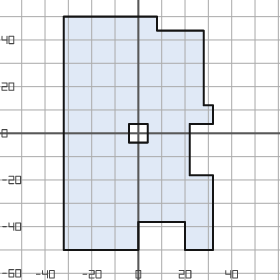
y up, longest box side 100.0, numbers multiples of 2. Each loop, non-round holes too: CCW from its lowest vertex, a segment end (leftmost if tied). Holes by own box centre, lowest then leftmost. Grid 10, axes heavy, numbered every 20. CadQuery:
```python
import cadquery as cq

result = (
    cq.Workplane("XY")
    .moveTo(-32.0, -50.0)
    .lineTo(0.0, -50.0)
    .lineTo(0.0, -38.0)
    .lineTo(20.0, -38.0)
    .lineTo(20.0, -50.0)
    .lineTo(32.0, -50.0)
    .lineTo(32.0, -18.0)
    .lineTo(22.0, -18.0)
    .lineTo(22.0, 4.0)
    .lineTo(32.0, 4.0)
    .lineTo(32.0, 12.0)
    .lineTo(28.0, 12.0)
    .lineTo(28.0, 44.0)
    .lineTo(8.0, 44.0)
    .lineTo(8.0, 50.0)
    .lineTo(-32.0, 50.0)
    .close()
    .moveTo(-4.0, -4.0)
    .lineTo(4.0, -4.0)
    .lineTo(4.0, 4.0)
    .lineTo(-4.0, 4.0)
    .close()
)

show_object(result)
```